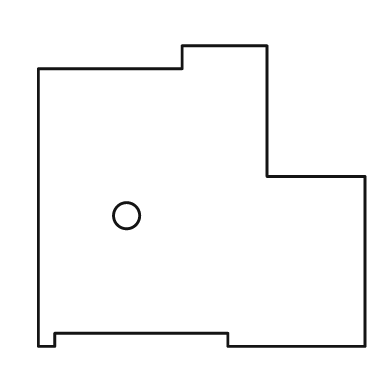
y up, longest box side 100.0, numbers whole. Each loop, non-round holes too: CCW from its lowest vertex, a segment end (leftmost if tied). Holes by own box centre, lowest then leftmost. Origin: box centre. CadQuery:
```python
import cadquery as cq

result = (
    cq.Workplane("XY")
    .moveTo(-50.0, -46.0)
    .lineTo(-45.0, -46.0)
    .lineTo(-45.0, -42.0)
    .lineTo(8.0, -42.0)
    .lineTo(8.0, -46.0)
    .lineTo(50.0, -46.0)
    .lineTo(50.0, 6.0)
    .lineTo(20.0, 6.0)
    .lineTo(20.0, 46.0)
    .lineTo(-6.0, 46.0)
    .lineTo(-6.0, 39.0)
    .lineTo(-50.0, 39.0)
    .close()
    .moveTo(-23.0, -6.0)
    .circle(4.0)
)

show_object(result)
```